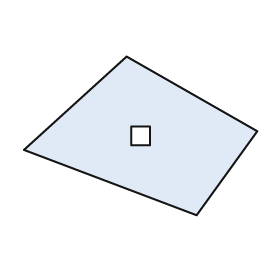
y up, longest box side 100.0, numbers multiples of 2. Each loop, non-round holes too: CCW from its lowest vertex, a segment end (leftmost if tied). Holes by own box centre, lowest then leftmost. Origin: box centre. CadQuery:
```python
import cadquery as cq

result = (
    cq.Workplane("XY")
    .moveTo(24.0, -34.0)
    .lineTo(50.0, 2.0)
    .lineTo(-6.0, 34.0)
    .lineTo(-50.0, -6.0)
    .close()
    .moveTo(-4.0, -4.0)
    .lineTo(4.0, -4.0)
    .lineTo(4.0, 4.0)
    .lineTo(-4.0, 4.0)
    .close()
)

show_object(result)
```